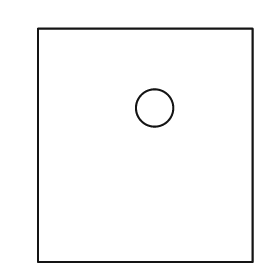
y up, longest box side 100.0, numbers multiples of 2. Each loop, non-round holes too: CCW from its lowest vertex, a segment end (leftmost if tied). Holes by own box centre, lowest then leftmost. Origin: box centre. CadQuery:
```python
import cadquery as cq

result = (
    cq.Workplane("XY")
    .moveTo(-46.0, -50.0)
    .lineTo(46.0, -50.0)
    .lineTo(46.0, 50.0)
    .lineTo(-46.0, 50.0)
    .close()
    .moveTo(4.0, 16.0)
    .circle(8.0)
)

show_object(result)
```